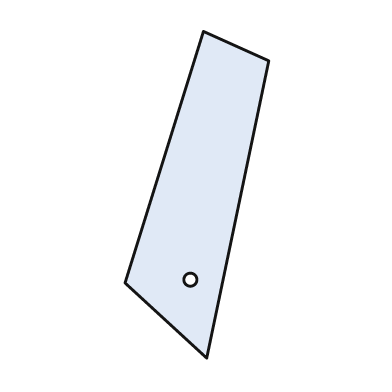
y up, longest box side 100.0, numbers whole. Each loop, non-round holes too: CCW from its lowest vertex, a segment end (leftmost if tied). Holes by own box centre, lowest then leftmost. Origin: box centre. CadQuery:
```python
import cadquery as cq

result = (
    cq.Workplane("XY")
    .moveTo(3.0, -50.0)
    .lineTo(22.0, 41.0)
    .lineTo(2.0, 50.0)
    .lineTo(-22.0, -27.0)
    .close()
    .moveTo(-2.0, -26.0)
    .circle(2.0)
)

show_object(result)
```